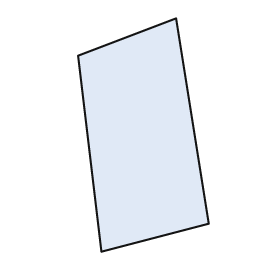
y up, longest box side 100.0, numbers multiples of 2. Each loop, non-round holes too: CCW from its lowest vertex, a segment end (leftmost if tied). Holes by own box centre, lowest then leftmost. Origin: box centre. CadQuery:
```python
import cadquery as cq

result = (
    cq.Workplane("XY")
    .moveTo(-18.0, -50.0)
    .lineTo(28.0, -38.0)
    .lineTo(14.0, 50.0)
    .lineTo(-28.0, 34.0)
    .close()
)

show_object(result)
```